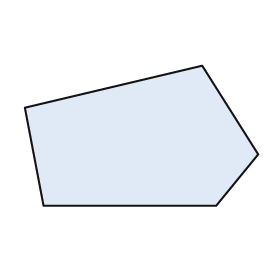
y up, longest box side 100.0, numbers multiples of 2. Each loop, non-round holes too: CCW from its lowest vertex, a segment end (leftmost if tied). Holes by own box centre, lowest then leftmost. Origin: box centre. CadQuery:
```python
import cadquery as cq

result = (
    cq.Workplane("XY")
    .moveTo(-42.0, -30.0)
    .lineTo(32.0, -30.0)
    .lineTo(50.0, -8.0)
    .lineTo(26.0, 30.0)
    .lineTo(-50.0, 12.0)
    .close()
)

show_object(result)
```